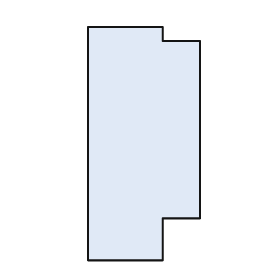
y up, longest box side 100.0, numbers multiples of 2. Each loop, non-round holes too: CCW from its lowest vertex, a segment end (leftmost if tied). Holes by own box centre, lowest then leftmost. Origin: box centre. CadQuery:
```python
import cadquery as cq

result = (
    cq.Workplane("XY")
    .moveTo(-24.0, -50.0)
    .lineTo(8.0, -50.0)
    .lineTo(8.0, -32.0)
    .lineTo(24.0, -32.0)
    .lineTo(24.0, 44.0)
    .lineTo(8.0, 44.0)
    .lineTo(8.0, 50.0)
    .lineTo(-24.0, 50.0)
    .close()
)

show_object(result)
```